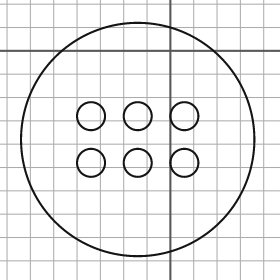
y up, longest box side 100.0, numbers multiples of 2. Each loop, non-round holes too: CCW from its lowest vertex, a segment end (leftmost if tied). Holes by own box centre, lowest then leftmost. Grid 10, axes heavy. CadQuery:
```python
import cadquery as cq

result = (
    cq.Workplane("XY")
    .moveTo(-14.0, -38.0)
    .circle(50.0)
    .moveTo(-34.0, -48.0)
    .circle(6.0)
    .moveTo(-14.0, -48.0)
    .circle(6.0)
    .moveTo(6.0, -48.0)
    .circle(6.0)
    .moveTo(-34.0, -28.0)
    .circle(6.0)
    .moveTo(-14.0, -28.0)
    .circle(6.0)
    .moveTo(6.0, -28.0)
    .circle(6.0)
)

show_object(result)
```